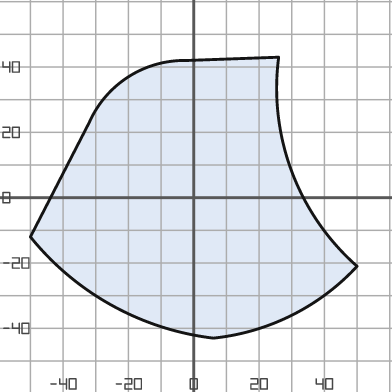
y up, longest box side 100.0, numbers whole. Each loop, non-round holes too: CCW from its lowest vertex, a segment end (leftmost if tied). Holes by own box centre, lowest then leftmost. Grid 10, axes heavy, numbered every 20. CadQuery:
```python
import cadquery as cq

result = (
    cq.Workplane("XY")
    .moveTo(6.0, -43.0)
    .threePointArc((30.0, -36.0), (50.0, -21.0))
    .threePointArc((30.0, 8.0), (26.0, 43.0))
    .lineTo(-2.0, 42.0)
    .threePointArc((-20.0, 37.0), (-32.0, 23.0))
    .lineTo(-50.0, -12.0)
    .threePointArc((-25.0, -33.0), (6.0, -43.0))
    .close()
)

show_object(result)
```